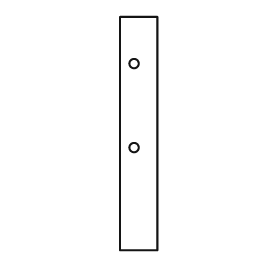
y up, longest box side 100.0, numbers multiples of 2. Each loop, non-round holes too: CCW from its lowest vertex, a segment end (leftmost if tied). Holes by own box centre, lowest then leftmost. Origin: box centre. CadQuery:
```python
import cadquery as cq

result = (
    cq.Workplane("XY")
    .moveTo(-8.0, -50.0)
    .lineTo(8.0, -50.0)
    .lineTo(8.0, 50.0)
    .lineTo(-8.0, 50.0)
    .close()
    .moveTo(-2.0, -6.0)
    .circle(2.0)
    .moveTo(-2.0, 30.0)
    .circle(2.0)
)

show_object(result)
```